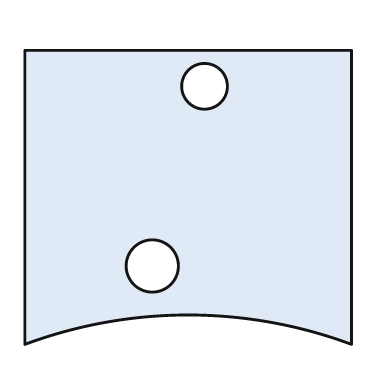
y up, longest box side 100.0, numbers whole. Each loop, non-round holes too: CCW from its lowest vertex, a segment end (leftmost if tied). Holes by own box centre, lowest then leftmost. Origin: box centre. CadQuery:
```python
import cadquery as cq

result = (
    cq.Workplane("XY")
    .moveTo(-50.0, -45.0)
    .threePointArc((0.0, -36.0), (50.0, -45.0))
    .lineTo(50.0, 45.0)
    .lineTo(-50.0, 45.0)
    .close()
    .moveTo(-11.0, -21.0)
    .circle(8.0)
    .moveTo(5.0, 34.0)
    .circle(7.0)
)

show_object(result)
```